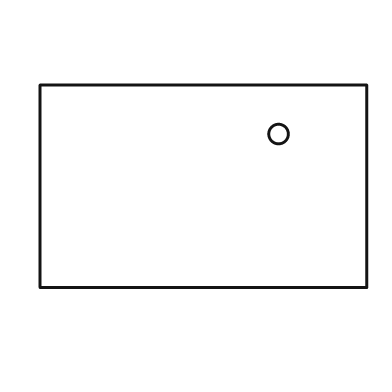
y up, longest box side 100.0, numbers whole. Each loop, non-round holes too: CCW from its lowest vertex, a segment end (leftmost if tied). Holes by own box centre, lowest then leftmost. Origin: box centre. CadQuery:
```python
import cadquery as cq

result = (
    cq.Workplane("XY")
    .moveTo(-50.0, -31.0)
    .lineTo(50.0, -31.0)
    .lineTo(50.0, 31.0)
    .lineTo(-50.0, 31.0)
    .close()
    .moveTo(23.0, 16.0)
    .circle(3.0)
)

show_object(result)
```